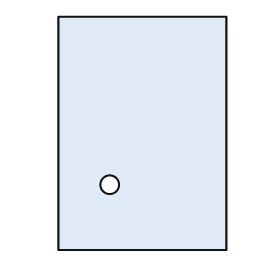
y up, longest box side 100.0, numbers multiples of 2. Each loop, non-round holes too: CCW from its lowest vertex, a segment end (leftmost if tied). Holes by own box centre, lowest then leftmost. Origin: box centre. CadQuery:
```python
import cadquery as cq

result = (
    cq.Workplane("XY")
    .moveTo(-36.0, -50.0)
    .lineTo(36.0, -50.0)
    .lineTo(36.0, 50.0)
    .lineTo(-36.0, 50.0)
    .close()
    .moveTo(-14.0, -22.0)
    .circle(4.0)
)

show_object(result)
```